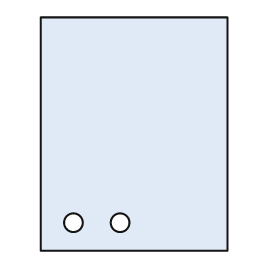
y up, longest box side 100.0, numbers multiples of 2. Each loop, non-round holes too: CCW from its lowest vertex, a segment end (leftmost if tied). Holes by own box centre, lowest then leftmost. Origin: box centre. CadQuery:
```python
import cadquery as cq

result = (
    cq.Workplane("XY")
    .moveTo(-40.0, -50.0)
    .lineTo(40.0, -50.0)
    .lineTo(40.0, 50.0)
    .lineTo(-40.0, 50.0)
    .close()
    .moveTo(-26.0, -38.0)
    .circle(4.0)
    .moveTo(-6.0, -38.0)
    .circle(4.0)
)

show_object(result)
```